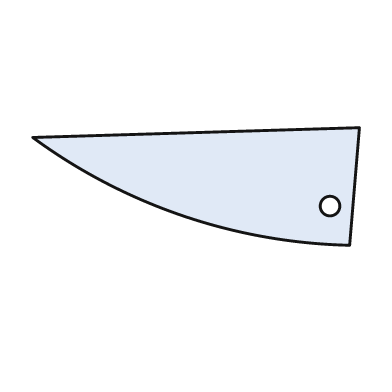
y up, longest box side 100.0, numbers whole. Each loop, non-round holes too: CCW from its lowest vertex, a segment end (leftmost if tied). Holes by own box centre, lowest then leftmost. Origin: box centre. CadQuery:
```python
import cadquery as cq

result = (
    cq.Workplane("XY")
    .moveTo(47.0, -18.0)
    .lineTo(50.0, 18.0)
    .lineTo(-50.0, 15.0)
    .threePointArc((-4.0, -9.0), (47.0, -18.0))
    .close()
    .moveTo(41.0, -6.0)
    .circle(3.0)
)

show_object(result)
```